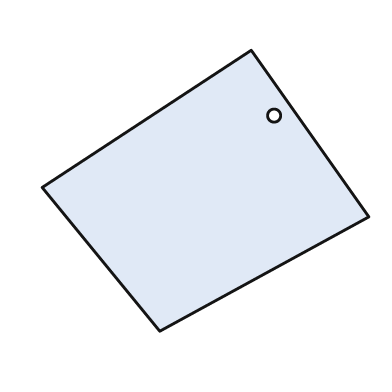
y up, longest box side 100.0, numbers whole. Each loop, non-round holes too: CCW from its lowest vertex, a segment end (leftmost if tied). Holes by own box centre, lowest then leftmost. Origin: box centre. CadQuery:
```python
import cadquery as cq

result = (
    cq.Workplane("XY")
    .moveTo(-14.0, -43.0)
    .lineTo(50.0, -8.0)
    .lineTo(14.0, 43.0)
    .lineTo(-50.0, 1.0)
    .close()
    .moveTo(21.0, 23.0)
    .circle(2.0)
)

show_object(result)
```